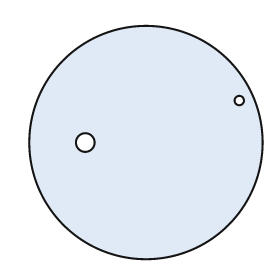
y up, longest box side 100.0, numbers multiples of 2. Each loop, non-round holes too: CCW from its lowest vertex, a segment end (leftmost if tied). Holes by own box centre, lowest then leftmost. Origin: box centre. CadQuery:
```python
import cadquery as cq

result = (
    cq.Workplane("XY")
    .moveTo(0.0, 0.0)
    .circle(50.0)
    .moveTo(-26.0, 0.0)
    .circle(4.0)
    .moveTo(40.0, 18.0)
    .circle(2.0)
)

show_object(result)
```